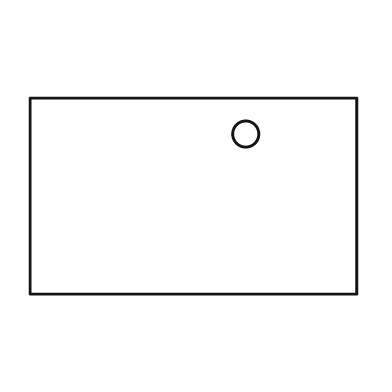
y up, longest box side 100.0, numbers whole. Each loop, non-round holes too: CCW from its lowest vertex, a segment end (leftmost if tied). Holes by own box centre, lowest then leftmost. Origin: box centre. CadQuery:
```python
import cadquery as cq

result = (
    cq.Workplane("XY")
    .moveTo(-50.0, -30.0)
    .lineTo(50.0, -30.0)
    .lineTo(50.0, 30.0)
    .lineTo(-50.0, 30.0)
    .close()
    .moveTo(16.0, 19.0)
    .circle(4.0)
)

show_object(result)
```